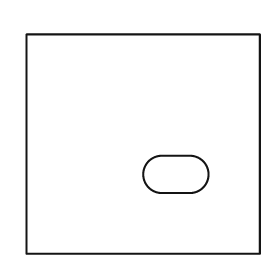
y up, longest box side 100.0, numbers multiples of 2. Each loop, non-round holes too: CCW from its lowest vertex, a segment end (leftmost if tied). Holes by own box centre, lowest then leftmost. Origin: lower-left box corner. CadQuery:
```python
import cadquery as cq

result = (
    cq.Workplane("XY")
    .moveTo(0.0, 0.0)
    .lineTo(100.0, 0.0)
    .lineTo(100.0, 94.0)
    .lineTo(0.0, 94.0)
    .close()
    .moveTo(58.0, 26.0)
    .lineTo(70.0, 26.0)
    .threePointArc((78.0, 34.0), (70.0, 42.0))
    .lineTo(58.0, 42.0)
    .threePointArc((50.0, 34.0), (58.0, 26.0))
    .close()
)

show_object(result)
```